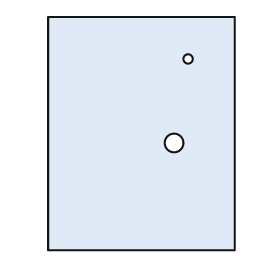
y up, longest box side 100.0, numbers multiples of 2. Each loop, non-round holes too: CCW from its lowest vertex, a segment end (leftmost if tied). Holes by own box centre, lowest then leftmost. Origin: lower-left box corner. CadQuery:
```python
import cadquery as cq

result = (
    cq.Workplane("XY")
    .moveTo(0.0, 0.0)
    .lineTo(80.0, 0.0)
    .lineTo(80.0, 100.0)
    .lineTo(0.0, 100.0)
    .close()
    .moveTo(54.0, 46.0)
    .circle(4.0)
    .moveTo(60.0, 82.0)
    .circle(2.0)
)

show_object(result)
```